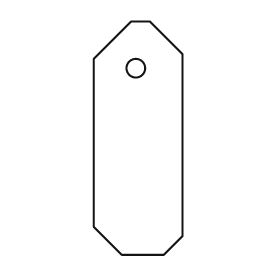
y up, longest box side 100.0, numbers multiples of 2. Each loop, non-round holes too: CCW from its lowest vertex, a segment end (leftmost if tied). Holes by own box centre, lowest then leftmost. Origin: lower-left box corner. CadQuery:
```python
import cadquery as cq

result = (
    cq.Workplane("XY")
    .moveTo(12.0, 0.0)
    .lineTo(30.0, 0.0)
    .lineTo(38.0, 8.0)
    .lineTo(38.0, 86.0)
    .lineTo(24.0, 100.0)
    .lineTo(16.0, 100.0)
    .lineTo(0.0, 84.0)
    .lineTo(0.0, 12.0)
    .close()
    .moveTo(18.0, 80.0)
    .circle(4.0)
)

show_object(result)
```